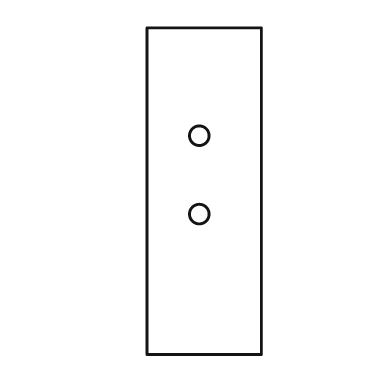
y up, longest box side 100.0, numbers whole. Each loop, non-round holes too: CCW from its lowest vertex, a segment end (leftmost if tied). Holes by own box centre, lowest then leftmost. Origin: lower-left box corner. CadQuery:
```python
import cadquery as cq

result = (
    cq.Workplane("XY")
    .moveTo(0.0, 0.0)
    .lineTo(35.0, 0.0)
    .lineTo(35.0, 100.0)
    .lineTo(0.0, 100.0)
    .close()
    .moveTo(16.0, 43.0)
    .circle(3.0)
    .moveTo(16.0, 67.0)
    .circle(3.0)
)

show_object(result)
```